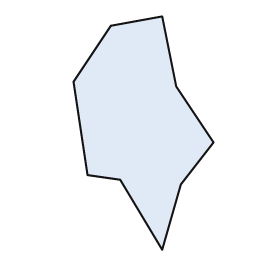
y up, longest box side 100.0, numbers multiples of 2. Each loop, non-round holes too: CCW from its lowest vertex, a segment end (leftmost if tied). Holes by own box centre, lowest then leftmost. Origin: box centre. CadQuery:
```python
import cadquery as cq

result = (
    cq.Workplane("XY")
    .moveTo(8.0, -50.0)
    .lineTo(16.0, -22.0)
    .lineTo(30.0, -4.0)
    .lineTo(14.0, 20.0)
    .lineTo(8.0, 50.0)
    .lineTo(-14.0, 46.0)
    .lineTo(-30.0, 22.0)
    .lineTo(-24.0, -18.0)
    .lineTo(-10.0, -20.0)
    .close()
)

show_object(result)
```